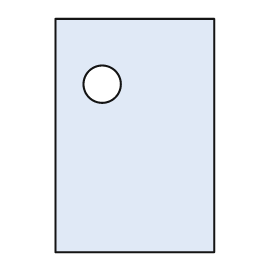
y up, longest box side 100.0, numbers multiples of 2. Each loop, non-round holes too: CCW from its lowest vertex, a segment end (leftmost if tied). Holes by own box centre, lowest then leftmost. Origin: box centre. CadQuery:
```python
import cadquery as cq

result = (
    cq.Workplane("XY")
    .moveTo(-34.0, -50.0)
    .lineTo(34.0, -50.0)
    .lineTo(34.0, 50.0)
    .lineTo(-34.0, 50.0)
    .close()
    .moveTo(-14.0, 22.0)
    .circle(8.0)
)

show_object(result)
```